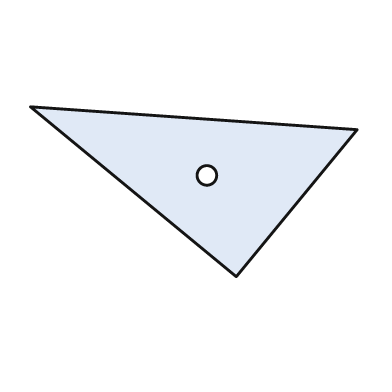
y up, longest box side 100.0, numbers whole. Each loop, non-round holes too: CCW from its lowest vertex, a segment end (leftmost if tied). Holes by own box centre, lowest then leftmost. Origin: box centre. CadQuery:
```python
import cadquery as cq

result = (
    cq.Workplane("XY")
    .moveTo(13.0, -26.0)
    .lineTo(50.0, 19.0)
    .lineTo(-50.0, 26.0)
    .close()
    .moveTo(4.0, 5.0)
    .circle(3.0)
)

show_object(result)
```